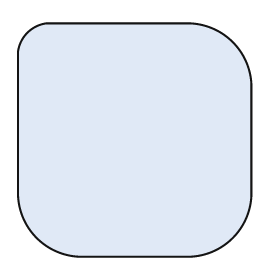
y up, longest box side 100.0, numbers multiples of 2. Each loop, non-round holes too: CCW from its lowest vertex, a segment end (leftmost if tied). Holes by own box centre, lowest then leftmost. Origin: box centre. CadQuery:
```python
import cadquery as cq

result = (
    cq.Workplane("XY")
    .moveTo(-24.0, -50.0)
    .lineTo(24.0, -50.0)
    .threePointArc((42.0, -42.0), (50.0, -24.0))
    .lineTo(50.0, 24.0)
    .threePointArc((42.0, 42.0), (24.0, 50.0))
    .lineTo(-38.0, 50.0)
    .threePointArc((-46.0, 46.0), (-50.0, 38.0))
    .lineTo(-50.0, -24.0)
    .threePointArc((-42.0, -42.0), (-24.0, -50.0))
    .close()
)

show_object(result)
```